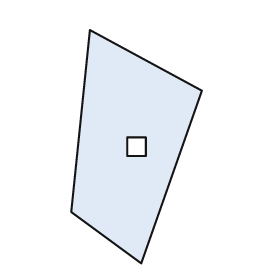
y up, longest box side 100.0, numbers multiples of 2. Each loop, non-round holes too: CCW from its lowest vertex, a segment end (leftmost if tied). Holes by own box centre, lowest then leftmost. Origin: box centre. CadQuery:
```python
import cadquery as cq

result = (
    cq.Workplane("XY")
    .moveTo(2.0, -50.0)
    .lineTo(28.0, 24.0)
    .lineTo(-20.0, 50.0)
    .lineTo(-28.0, -28.0)
    .close()
    .moveTo(-4.0, -4.0)
    .lineTo(4.0, -4.0)
    .lineTo(4.0, 4.0)
    .lineTo(-4.0, 4.0)
    .close()
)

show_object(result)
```